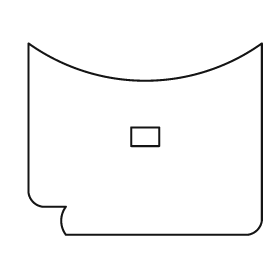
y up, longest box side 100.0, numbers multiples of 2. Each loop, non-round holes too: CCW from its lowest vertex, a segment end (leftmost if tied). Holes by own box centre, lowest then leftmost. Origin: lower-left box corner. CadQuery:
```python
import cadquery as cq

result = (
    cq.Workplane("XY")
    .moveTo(16.0, 0.0)
    .lineTo(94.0, 0.0)
    .threePointArc((98.0, 2.0), (100.0, 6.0))
    .lineTo(100.0, 82.0)
    .threePointArc((50.0, 66.0), (0.0, 82.0))
    .lineTo(0.0, 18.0)
    .threePointArc((2.0, 14.0), (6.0, 12.0))
    .lineTo(16.0, 12.0)
    .threePointArc((14.0, 6.0), (16.0, 0.0))
    .close()
    .moveTo(44.0, 38.0)
    .lineTo(56.0, 38.0)
    .lineTo(56.0, 46.0)
    .lineTo(44.0, 46.0)
    .close()
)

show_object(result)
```